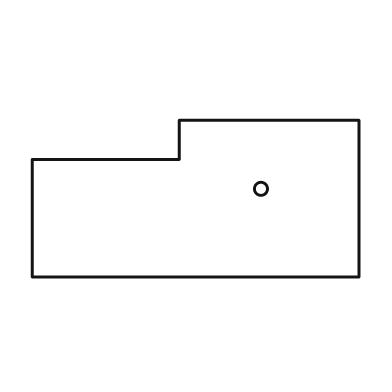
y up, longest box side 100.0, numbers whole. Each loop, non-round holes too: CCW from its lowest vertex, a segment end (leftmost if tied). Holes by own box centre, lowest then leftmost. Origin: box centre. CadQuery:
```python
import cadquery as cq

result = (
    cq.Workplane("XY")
    .moveTo(-50.0, -24.0)
    .lineTo(50.0, -24.0)
    .lineTo(50.0, 24.0)
    .lineTo(-5.0, 24.0)
    .lineTo(-5.0, 12.0)
    .lineTo(-50.0, 12.0)
    .close()
    .moveTo(20.0, 3.0)
    .circle(2.0)
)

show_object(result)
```